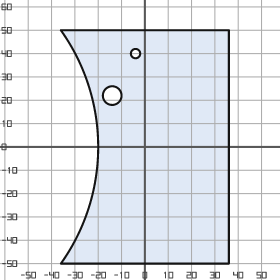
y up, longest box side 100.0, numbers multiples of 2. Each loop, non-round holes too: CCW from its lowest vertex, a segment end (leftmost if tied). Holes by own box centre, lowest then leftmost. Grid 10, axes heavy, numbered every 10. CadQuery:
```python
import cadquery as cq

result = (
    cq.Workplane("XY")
    .moveTo(-36.0, -50.0)
    .lineTo(36.0, -50.0)
    .lineTo(36.0, 50.0)
    .lineTo(-36.0, 50.0)
    .threePointArc((-20.0, 0.0), (-36.0, -50.0))
    .close()
    .moveTo(-14.0, 22.0)
    .circle(4.0)
    .moveTo(-4.0, 40.0)
    .circle(2.0)
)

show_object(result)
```